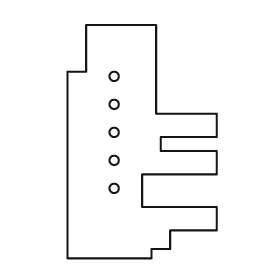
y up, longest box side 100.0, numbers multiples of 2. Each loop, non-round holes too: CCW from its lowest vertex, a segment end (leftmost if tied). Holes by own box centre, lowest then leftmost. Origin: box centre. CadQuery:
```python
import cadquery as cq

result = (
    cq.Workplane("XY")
    .moveTo(-32.0, -50.0)
    .lineTo(4.0, -50.0)
    .lineTo(4.0, -46.0)
    .lineTo(12.0, -46.0)
    .lineTo(12.0, -38.0)
    .lineTo(32.0, -38.0)
    .lineTo(32.0, -28.0)
    .lineTo(0.0, -28.0)
    .lineTo(0.0, -14.0)
    .lineTo(32.0, -14.0)
    .lineTo(32.0, -4.0)
    .lineTo(8.0, -4.0)
    .lineTo(8.0, 2.0)
    .lineTo(32.0, 2.0)
    .lineTo(32.0, 12.0)
    .lineTo(6.0, 12.0)
    .lineTo(6.0, 50.0)
    .lineTo(-24.0, 50.0)
    .lineTo(-24.0, 30.0)
    .lineTo(-32.0, 30.0)
    .close()
    .moveTo(-12.0, -20.0)
    .circle(2.0)
    .moveTo(-12.0, -8.0)
    .circle(2.0)
    .moveTo(-12.0, 4.0)
    .circle(2.0)
    .moveTo(-12.0, 16.0)
    .circle(2.0)
    .moveTo(-12.0, 28.0)
    .circle(2.0)
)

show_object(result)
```